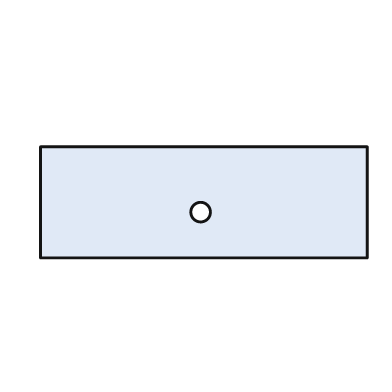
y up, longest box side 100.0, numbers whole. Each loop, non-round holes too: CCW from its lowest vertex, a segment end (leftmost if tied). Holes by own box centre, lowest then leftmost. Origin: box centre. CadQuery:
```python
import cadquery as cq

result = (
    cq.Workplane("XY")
    .moveTo(-50.0, -17.0)
    .lineTo(50.0, -17.0)
    .lineTo(50.0, 17.0)
    .lineTo(-50.0, 17.0)
    .close()
    .moveTo(-1.0, -3.0)
    .circle(3.0)
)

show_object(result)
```